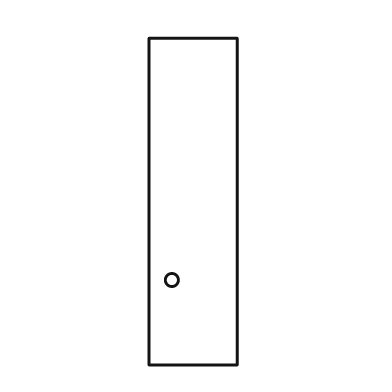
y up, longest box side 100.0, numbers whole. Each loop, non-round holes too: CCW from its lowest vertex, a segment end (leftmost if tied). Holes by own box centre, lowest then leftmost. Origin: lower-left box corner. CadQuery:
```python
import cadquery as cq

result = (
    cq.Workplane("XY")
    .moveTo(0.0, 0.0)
    .lineTo(27.0, 0.0)
    .lineTo(27.0, 100.0)
    .lineTo(0.0, 100.0)
    .close()
    .moveTo(7.0, 26.0)
    .circle(2.0)
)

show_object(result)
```